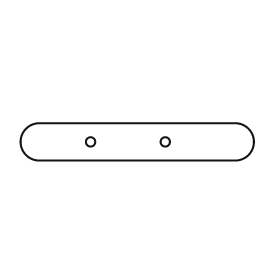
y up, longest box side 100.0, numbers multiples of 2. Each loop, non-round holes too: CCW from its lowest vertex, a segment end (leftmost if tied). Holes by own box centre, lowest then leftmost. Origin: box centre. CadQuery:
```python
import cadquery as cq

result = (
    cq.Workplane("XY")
    .moveTo(-42.0, -8.0)
    .lineTo(42.0, -8.0)
    .threePointArc((50.0, 0.0), (42.0, 8.0))
    .lineTo(-42.0, 8.0)
    .threePointArc((-50.0, 0.0), (-42.0, -8.0))
    .close()
    .moveTo(-20.0, 0.0)
    .circle(2.0)
    .moveTo(12.0, 0.0)
    .circle(2.0)
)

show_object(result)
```